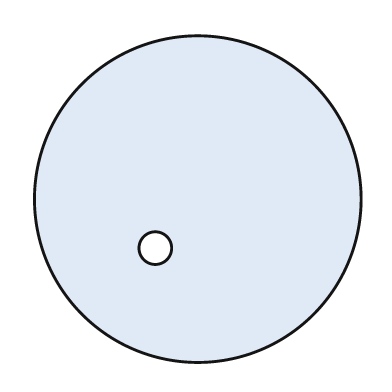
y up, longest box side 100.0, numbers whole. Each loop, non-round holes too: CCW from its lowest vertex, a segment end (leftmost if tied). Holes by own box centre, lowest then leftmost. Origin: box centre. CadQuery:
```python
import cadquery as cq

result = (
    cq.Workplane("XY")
    .moveTo(0.0, 0.0)
    .circle(50.0)
    .moveTo(-13.0, -15.0)
    .circle(5.0)
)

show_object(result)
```